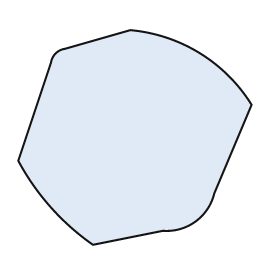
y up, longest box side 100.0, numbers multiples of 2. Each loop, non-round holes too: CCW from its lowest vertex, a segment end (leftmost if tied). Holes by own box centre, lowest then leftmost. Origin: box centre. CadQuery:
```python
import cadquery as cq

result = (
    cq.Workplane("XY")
    .moveTo(-18.0, -46.0)
    .lineTo(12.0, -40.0)
    .threePointArc((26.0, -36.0), (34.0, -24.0))
    .lineTo(50.0, 14.0)
    .threePointArc((28.0, 36.0), (-2.0, 46.0))
    .lineTo(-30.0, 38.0)
    .threePointArc((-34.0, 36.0), (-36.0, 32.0))
    .lineTo(-50.0, -10.0)
    .threePointArc((-36.0, -30.0), (-18.0, -46.0))
    .close()
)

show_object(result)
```